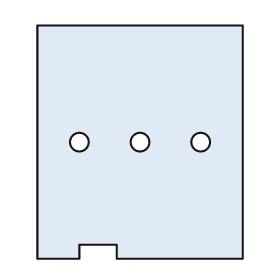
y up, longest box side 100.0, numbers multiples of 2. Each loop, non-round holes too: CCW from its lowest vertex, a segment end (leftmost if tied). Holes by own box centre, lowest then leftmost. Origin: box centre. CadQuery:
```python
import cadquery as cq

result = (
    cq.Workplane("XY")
    .moveTo(-44.0, -50.0)
    .lineTo(-26.0, -50.0)
    .lineTo(-26.0, -44.0)
    .lineTo(-10.0, -44.0)
    .lineTo(-10.0, -50.0)
    .lineTo(44.0, -50.0)
    .lineTo(44.0, 50.0)
    .lineTo(-44.0, 50.0)
    .close()
    .moveTo(-26.0, 0.0)
    .circle(4.0)
    .moveTo(0.0, 0.0)
    .circle(4.0)
    .moveTo(26.0, 0.0)
    .circle(4.0)
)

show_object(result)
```